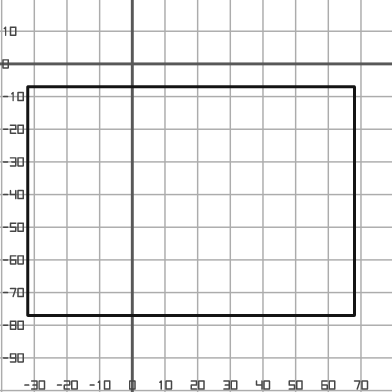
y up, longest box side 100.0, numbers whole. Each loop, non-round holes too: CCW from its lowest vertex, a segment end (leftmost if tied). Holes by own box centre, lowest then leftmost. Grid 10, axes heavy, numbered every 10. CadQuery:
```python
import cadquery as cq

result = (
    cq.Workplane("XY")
    .moveTo(-32.0, -77.0)
    .lineTo(68.0, -77.0)
    .lineTo(68.0, -7.0)
    .lineTo(-32.0, -7.0)
    .close()
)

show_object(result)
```